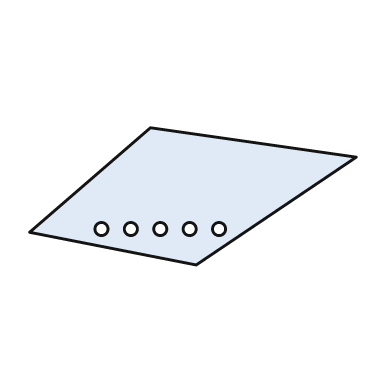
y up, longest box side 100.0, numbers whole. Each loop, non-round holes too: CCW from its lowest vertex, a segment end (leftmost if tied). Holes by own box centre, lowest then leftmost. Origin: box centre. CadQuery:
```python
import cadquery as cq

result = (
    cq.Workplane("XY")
    .moveTo(1.0, -21.0)
    .lineTo(50.0, 12.0)
    .lineTo(-13.0, 21.0)
    .lineTo(-50.0, -11.0)
    .close()
    .moveTo(-28.0, -10.0)
    .circle(2.0)
    .moveTo(-19.0, -10.0)
    .circle(2.0)
    .moveTo(-10.0, -10.0)
    .circle(2.0)
    .moveTo(-1.0, -10.0)
    .circle(2.0)
    .moveTo(8.0, -10.0)
    .circle(2.0)
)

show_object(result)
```